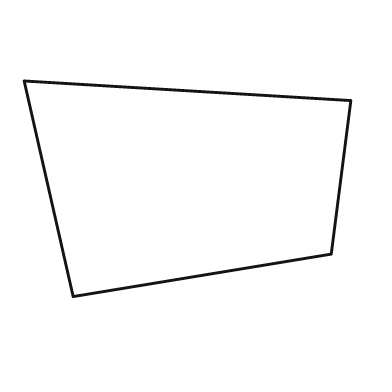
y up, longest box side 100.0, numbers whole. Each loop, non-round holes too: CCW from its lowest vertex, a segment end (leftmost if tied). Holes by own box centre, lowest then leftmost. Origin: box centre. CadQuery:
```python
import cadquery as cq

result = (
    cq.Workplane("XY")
    .moveTo(-35.0, -33.0)
    .lineTo(44.0, -20.0)
    .lineTo(50.0, 27.0)
    .lineTo(-50.0, 33.0)
    .close()
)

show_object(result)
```